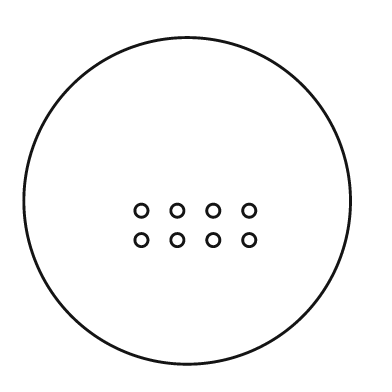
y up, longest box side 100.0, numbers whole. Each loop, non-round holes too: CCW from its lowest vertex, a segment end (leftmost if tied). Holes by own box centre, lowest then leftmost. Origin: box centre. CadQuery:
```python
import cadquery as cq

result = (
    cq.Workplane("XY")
    .moveTo(0.0, 0.0)
    .circle(50.0)
    .moveTo(-14.0, -12.0)
    .circle(2.0)
    .moveTo(-3.0, -12.0)
    .circle(2.0)
    .moveTo(8.0, -12.0)
    .circle(2.0)
    .moveTo(19.0, -12.0)
    .circle(2.0)
    .moveTo(-14.0, -3.0)
    .circle(2.0)
    .moveTo(-3.0, -3.0)
    .circle(2.0)
    .moveTo(8.0, -3.0)
    .circle(2.0)
    .moveTo(19.0, -3.0)
    .circle(2.0)
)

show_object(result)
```